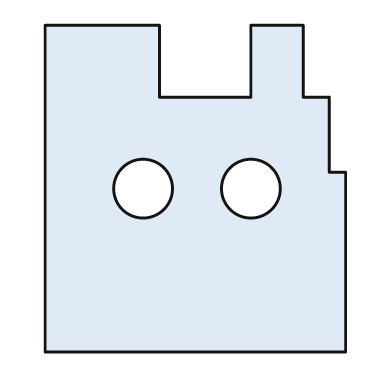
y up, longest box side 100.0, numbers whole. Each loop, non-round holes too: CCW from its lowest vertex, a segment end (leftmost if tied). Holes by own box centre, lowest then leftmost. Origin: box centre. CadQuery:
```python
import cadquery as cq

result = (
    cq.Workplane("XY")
    .moveTo(-46.0, -50.0)
    .lineTo(46.0, -50.0)
    .lineTo(46.0, 5.0)
    .lineTo(41.0, 5.0)
    .lineTo(41.0, 28.0)
    .lineTo(33.0, 28.0)
    .lineTo(33.0, 50.0)
    .lineTo(17.0, 50.0)
    .lineTo(17.0, 28.0)
    .lineTo(-11.0, 28.0)
    .lineTo(-11.0, 50.0)
    .lineTo(-46.0, 50.0)
    .close()
    .moveTo(-16.0, 0.0)
    .circle(9.0)
    .moveTo(17.0, 0.0)
    .circle(9.0)
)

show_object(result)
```